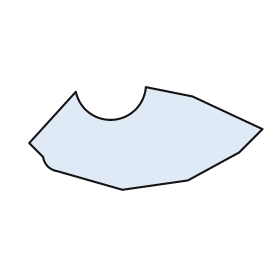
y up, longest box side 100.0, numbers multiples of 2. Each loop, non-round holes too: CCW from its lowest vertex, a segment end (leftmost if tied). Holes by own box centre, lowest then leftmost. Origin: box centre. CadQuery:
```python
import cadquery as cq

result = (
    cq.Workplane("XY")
    .moveTo(-10.0, -22.0)
    .lineTo(18.0, -18.0)
    .lineTo(40.0, -6.0)
    .lineTo(50.0, 4.0)
    .lineTo(20.0, 18.0)
    .lineTo(0.0, 22.0)
    .threePointArc((-14.0, 8.0), (-30.0, 20.0))
    .lineTo(-50.0, -2.0)
    .lineTo(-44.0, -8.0)
    .threePointArc((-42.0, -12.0), (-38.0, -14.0))
    .close()
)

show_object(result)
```